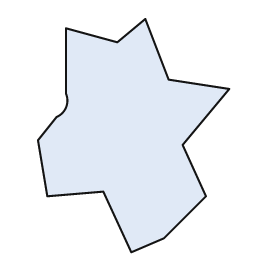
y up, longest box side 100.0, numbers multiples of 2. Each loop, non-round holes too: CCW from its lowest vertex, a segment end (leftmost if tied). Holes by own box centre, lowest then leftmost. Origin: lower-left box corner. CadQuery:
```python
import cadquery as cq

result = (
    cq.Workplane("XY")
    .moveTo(40.0, 0.0)
    .lineTo(54.0, 6.0)
    .lineTo(72.0, 24.0)
    .lineTo(62.0, 46.0)
    .lineTo(82.0, 70.0)
    .lineTo(56.0, 74.0)
    .lineTo(46.0, 100.0)
    .lineTo(34.0, 90.0)
    .lineTo(12.0, 96.0)
    .lineTo(12.0, 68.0)
    .threePointArc((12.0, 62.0), (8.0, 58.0))
    .lineTo(0.0, 48.0)
    .lineTo(4.0, 24.0)
    .lineTo(28.0, 26.0)
    .close()
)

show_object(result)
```